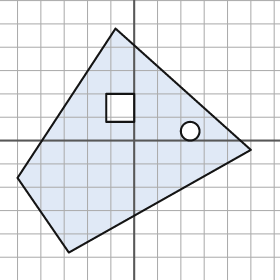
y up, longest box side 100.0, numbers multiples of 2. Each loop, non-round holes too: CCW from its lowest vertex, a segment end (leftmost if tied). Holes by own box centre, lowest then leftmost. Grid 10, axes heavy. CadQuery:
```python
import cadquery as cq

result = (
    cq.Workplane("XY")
    .moveTo(-28.0, -48.0)
    .lineTo(50.0, -4.0)
    .lineTo(-8.0, 48.0)
    .lineTo(-50.0, -16.0)
    .close()
    .moveTo(24.0, 4.0)
    .circle(4.0)
    .moveTo(-12.0, 8.0)
    .lineTo(0.0, 8.0)
    .lineTo(0.0, 20.0)
    .lineTo(-12.0, 20.0)
    .close()
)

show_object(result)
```